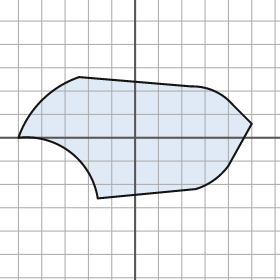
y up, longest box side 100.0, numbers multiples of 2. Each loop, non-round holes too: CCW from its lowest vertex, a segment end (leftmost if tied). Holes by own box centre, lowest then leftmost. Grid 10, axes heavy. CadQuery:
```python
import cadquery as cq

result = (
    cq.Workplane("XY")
    .moveTo(-16.0, -26.0)
    .lineTo(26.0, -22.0)
    .threePointArc((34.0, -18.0), (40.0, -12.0))
    .lineTo(50.0, 6.0)
    .lineTo(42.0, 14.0)
    .threePointArc((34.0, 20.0), (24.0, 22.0))
    .lineTo(-24.0, 26.0)
    .threePointArc((-40.0, 16.0), (-50.0, 0.0))
    .threePointArc((-28.0, -6.0), (-16.0, -26.0))
    .close()
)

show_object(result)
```